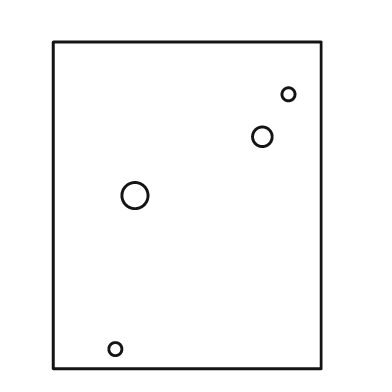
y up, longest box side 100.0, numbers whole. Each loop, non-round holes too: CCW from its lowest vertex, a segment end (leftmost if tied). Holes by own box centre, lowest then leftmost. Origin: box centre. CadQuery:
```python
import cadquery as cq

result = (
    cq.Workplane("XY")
    .moveTo(-41.0, -50.0)
    .lineTo(41.0, -50.0)
    .lineTo(41.0, 50.0)
    .lineTo(-41.0, 50.0)
    .close()
    .moveTo(-22.0, -44.0)
    .circle(2.0)
    .moveTo(-16.0, 3.0)
    .circle(4.0)
    .moveTo(23.0, 21.0)
    .circle(3.0)
    .moveTo(31.0, 34.0)
    .circle(2.0)
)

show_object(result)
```